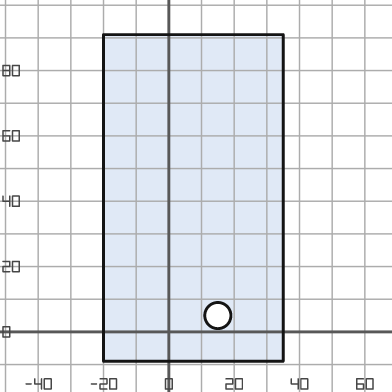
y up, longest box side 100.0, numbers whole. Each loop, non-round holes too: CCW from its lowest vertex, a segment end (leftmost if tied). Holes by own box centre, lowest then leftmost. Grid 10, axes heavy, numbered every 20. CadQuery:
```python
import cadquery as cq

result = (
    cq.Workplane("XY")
    .moveTo(-20.0, -9.0)
    .lineTo(35.0, -9.0)
    .lineTo(35.0, 91.0)
    .lineTo(-20.0, 91.0)
    .close()
    .moveTo(15.0, 5.0)
    .circle(4.0)
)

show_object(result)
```